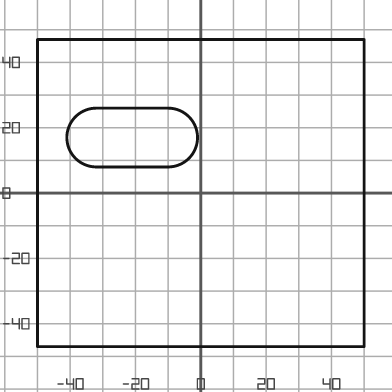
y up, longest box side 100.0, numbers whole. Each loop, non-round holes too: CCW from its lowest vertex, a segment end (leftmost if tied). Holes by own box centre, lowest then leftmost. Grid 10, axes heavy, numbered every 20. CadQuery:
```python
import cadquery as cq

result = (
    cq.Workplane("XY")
    .moveTo(-50.0, -47.0)
    .lineTo(50.0, -47.0)
    .lineTo(50.0, 47.0)
    .lineTo(-50.0, 47.0)
    .close()
    .moveTo(-32.0, 8.0)
    .lineTo(-10.0, 8.0)
    .threePointArc((-1.0, 17.0), (-10.0, 26.0))
    .lineTo(-32.0, 26.0)
    .threePointArc((-41.0, 17.0), (-32.0, 8.0))
    .close()
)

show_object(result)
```